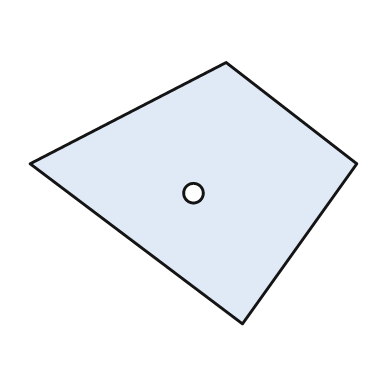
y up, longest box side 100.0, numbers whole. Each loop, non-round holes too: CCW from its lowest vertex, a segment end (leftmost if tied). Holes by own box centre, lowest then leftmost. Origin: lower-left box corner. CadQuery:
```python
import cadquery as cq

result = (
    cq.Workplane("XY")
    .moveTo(65.0, 0.0)
    .lineTo(100.0, 49.0)
    .lineTo(60.0, 80.0)
    .lineTo(0.0, 49.0)
    .close()
    .moveTo(50.0, 40.0)
    .circle(3.0)
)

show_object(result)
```